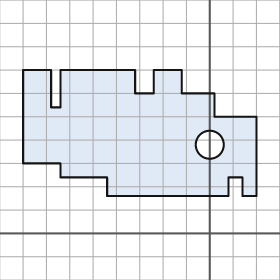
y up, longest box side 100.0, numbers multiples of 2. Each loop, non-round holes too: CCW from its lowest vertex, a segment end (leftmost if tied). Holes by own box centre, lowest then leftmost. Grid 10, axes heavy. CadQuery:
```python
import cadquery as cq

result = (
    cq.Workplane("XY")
    .moveTo(-44.0, 16.0)
    .lineTo(8.0, 16.0)
    .lineTo(8.0, 24.0)
    .lineTo(14.0, 24.0)
    .lineTo(14.0, 16.0)
    .lineTo(20.0, 16.0)
    .lineTo(20.0, 50.0)
    .lineTo(2.0, 50.0)
    .lineTo(2.0, 60.0)
    .lineTo(-12.0, 60.0)
    .lineTo(-12.0, 70.0)
    .lineTo(-24.0, 70.0)
    .lineTo(-24.0, 60.0)
    .lineTo(-32.0, 60.0)
    .lineTo(-32.0, 70.0)
    .lineTo(-64.0, 70.0)
    .lineTo(-64.0, 54.0)
    .lineTo(-68.0, 54.0)
    .lineTo(-68.0, 70.0)
    .lineTo(-80.0, 70.0)
    .lineTo(-80.0, 30.0)
    .lineTo(-64.0, 30.0)
    .lineTo(-64.0, 24.0)
    .lineTo(-44.0, 24.0)
    .close()
    .moveTo(0.0, 38.0)
    .circle(6.0)
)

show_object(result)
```